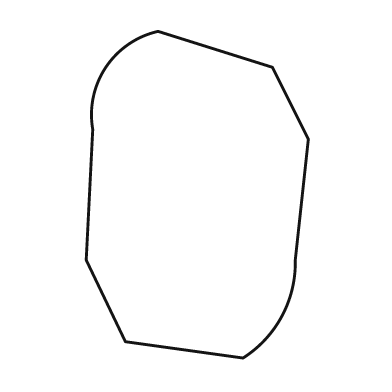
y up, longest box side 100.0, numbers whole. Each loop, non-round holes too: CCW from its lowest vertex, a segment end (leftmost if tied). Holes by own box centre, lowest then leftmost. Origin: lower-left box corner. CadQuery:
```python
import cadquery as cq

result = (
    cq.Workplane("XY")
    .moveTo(48.0, 0.0)
    .threePointArc((60.0, 13.0), (64.0, 30.0))
    .lineTo(68.0, 67.0)
    .lineTo(57.0, 89.0)
    .lineTo(22.0, 100.0)
    .threePointArc((6.0, 89.0), (2.0, 70.0))
    .lineTo(0.0, 30.0)
    .lineTo(12.0, 5.0)
    .close()
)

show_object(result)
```